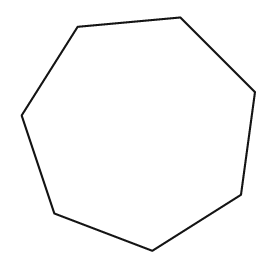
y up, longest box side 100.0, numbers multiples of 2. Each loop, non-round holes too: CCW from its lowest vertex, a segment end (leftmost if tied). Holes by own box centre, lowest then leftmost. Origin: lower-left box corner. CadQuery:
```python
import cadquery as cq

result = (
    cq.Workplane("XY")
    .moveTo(56.0, 0.0)
    .lineTo(94.0, 24.0)
    .lineTo(100.0, 68.0)
    .lineTo(68.0, 100.0)
    .lineTo(24.0, 96.0)
    .lineTo(0.0, 58.0)
    .lineTo(14.0, 16.0)
    .close()
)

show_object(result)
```